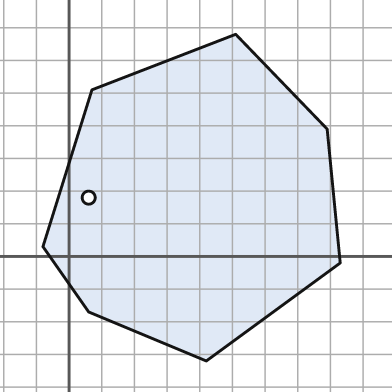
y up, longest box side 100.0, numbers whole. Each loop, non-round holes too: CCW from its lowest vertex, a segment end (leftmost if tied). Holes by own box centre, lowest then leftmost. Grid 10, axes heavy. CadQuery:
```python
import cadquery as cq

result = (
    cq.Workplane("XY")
    .moveTo(42.0, -32.0)
    .lineTo(83.0, -2.0)
    .lineTo(79.0, 39.0)
    .lineTo(51.0, 68.0)
    .lineTo(7.0, 51.0)
    .lineTo(-8.0, 3.0)
    .lineTo(6.0, -17.0)
    .close()
    .moveTo(6.0, 18.0)
    .circle(2.0)
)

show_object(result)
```